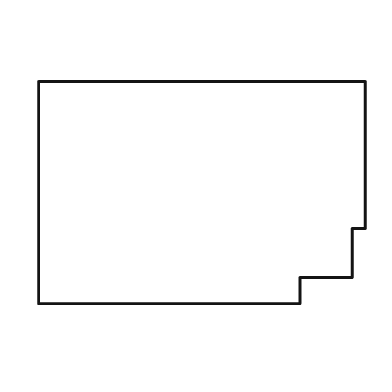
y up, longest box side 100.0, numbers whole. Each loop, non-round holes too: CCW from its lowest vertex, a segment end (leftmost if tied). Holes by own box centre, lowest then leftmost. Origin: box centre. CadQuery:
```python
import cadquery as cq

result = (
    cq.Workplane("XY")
    .moveTo(-50.0, -34.0)
    .lineTo(30.0, -34.0)
    .lineTo(30.0, -26.0)
    .lineTo(46.0, -26.0)
    .lineTo(46.0, -11.0)
    .lineTo(50.0, -11.0)
    .lineTo(50.0, 34.0)
    .lineTo(-50.0, 34.0)
    .close()
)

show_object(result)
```